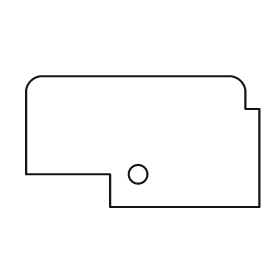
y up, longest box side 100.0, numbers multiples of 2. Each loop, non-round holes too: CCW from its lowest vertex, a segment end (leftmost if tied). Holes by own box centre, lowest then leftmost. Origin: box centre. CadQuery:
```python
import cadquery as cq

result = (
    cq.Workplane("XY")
    .moveTo(-14.0, -28.0)
    .lineTo(50.0, -28.0)
    .lineTo(50.0, 14.0)
    .lineTo(44.0, 14.0)
    .lineTo(44.0, 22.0)
    .threePointArc((42.0, 26.0), (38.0, 28.0))
    .lineTo(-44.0, 28.0)
    .threePointArc((-48.0, 26.0), (-50.0, 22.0))
    .lineTo(-50.0, -14.0)
    .lineTo(-14.0, -14.0)
    .close()
    .moveTo(-2.0, -14.0)
    .circle(4.0)
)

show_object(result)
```